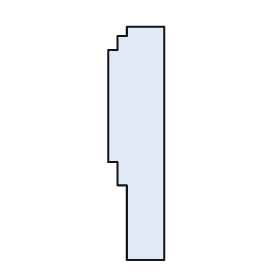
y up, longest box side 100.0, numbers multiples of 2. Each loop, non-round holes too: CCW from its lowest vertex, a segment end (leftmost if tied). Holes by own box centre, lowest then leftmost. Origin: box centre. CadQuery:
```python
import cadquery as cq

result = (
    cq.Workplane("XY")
    .moveTo(-4.0, -50.0)
    .lineTo(12.0, -50.0)
    .lineTo(12.0, 50.0)
    .lineTo(-4.0, 50.0)
    .lineTo(-4.0, 46.0)
    .lineTo(-8.0, 46.0)
    .lineTo(-8.0, 40.0)
    .lineTo(-12.0, 40.0)
    .lineTo(-12.0, -8.0)
    .lineTo(-8.0, -8.0)
    .lineTo(-8.0, -18.0)
    .lineTo(-4.0, -18.0)
    .close()
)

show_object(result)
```